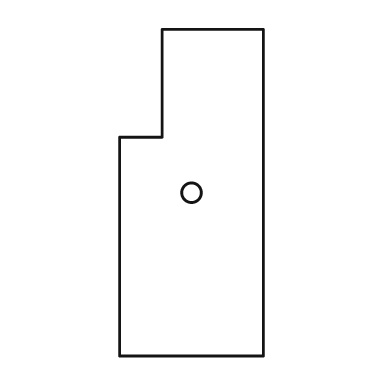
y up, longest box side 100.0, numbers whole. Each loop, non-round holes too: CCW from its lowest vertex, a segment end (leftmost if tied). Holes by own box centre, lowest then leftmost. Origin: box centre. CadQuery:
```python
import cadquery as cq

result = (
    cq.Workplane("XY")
    .moveTo(-22.0, -50.0)
    .lineTo(22.0, -50.0)
    .lineTo(22.0, 50.0)
    .lineTo(-9.0, 50.0)
    .lineTo(-9.0, 17.0)
    .lineTo(-22.0, 17.0)
    .close()
    .moveTo(0.0, 0.0)
    .circle(3.0)
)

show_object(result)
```